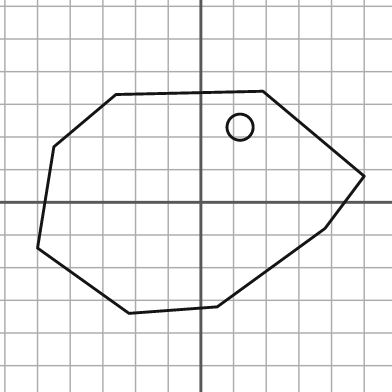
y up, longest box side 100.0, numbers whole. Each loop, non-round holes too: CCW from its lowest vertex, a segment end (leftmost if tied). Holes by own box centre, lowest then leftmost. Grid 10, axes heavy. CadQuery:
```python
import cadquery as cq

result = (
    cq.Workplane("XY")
    .moveTo(-22.0, -34.0)
    .lineTo(5.0, -32.0)
    .lineTo(38.0, -8.0)
    .lineTo(50.0, 8.0)
    .lineTo(19.0, 34.0)
    .lineTo(-26.0, 33.0)
    .lineTo(-45.0, 17.0)
    .lineTo(-50.0, -14.0)
    .close()
    .moveTo(12.0, 23.0)
    .circle(4.0)
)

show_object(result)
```